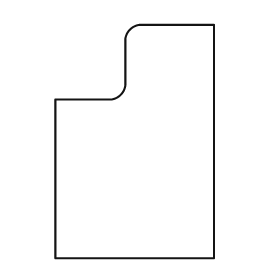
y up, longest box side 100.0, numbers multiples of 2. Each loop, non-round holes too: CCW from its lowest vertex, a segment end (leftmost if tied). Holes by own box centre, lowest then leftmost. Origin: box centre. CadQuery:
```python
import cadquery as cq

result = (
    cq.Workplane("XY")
    .moveTo(-34.0, -50.0)
    .lineTo(34.0, -50.0)
    .lineTo(34.0, 50.0)
    .lineTo(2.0, 50.0)
    .threePointArc((-2.0, 48.0), (-4.0, 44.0))
    .lineTo(-4.0, 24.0)
    .threePointArc((-6.0, 20.0), (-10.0, 18.0))
    .lineTo(-34.0, 18.0)
    .close()
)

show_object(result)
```